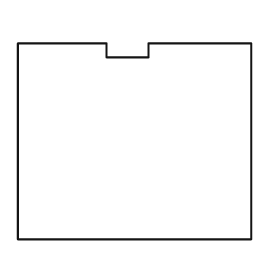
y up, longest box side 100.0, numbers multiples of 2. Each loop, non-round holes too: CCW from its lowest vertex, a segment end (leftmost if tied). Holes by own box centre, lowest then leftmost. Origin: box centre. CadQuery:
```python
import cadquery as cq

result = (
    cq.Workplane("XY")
    .moveTo(-50.0, -42.0)
    .lineTo(50.0, -42.0)
    .lineTo(50.0, 42.0)
    .lineTo(6.0, 42.0)
    .lineTo(6.0, 36.0)
    .lineTo(-12.0, 36.0)
    .lineTo(-12.0, 42.0)
    .lineTo(-50.0, 42.0)
    .close()
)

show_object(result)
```